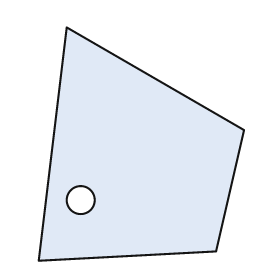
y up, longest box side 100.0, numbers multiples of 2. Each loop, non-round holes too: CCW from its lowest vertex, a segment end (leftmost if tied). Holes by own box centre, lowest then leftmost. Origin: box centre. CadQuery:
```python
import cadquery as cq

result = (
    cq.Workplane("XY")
    .moveTo(-44.0, -50.0)
    .lineTo(32.0, -46.0)
    .lineTo(44.0, 6.0)
    .lineTo(-32.0, 50.0)
    .close()
    .moveTo(-26.0, -24.0)
    .circle(6.0)
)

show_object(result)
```